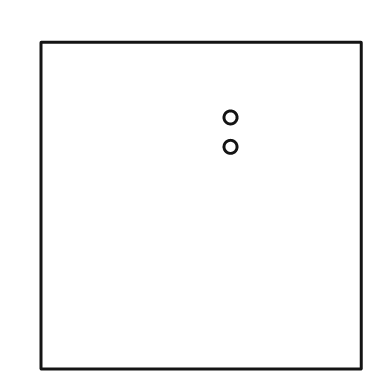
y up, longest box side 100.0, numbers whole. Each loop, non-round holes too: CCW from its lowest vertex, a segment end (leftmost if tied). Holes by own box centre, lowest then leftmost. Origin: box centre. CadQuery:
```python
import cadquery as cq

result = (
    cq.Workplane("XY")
    .moveTo(-49.0, -50.0)
    .lineTo(49.0, -50.0)
    .lineTo(49.0, 50.0)
    .lineTo(-49.0, 50.0)
    .close()
    .moveTo(9.0, 18.0)
    .circle(2.0)
    .moveTo(9.0, 27.0)
    .circle(2.0)
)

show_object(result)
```